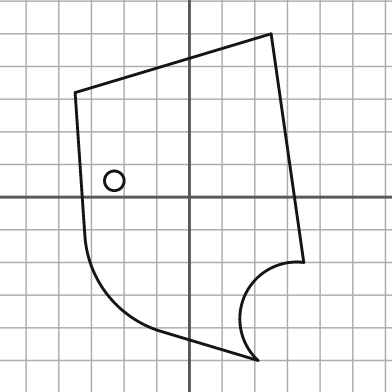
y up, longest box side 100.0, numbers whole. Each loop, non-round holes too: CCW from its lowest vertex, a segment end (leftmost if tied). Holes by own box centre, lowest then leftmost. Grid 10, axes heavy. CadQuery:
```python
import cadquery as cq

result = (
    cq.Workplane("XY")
    .moveTo(21.0, -50.0)
    .threePointArc((17.0, -30.0), (35.0, -20.0))
    .lineTo(25.0, 50.0)
    .lineTo(-35.0, 32.0)
    .lineTo(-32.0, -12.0)
    .threePointArc((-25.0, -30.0), (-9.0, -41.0))
    .close()
    .moveTo(-23.0, 5.0)
    .circle(3.0)
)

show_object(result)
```